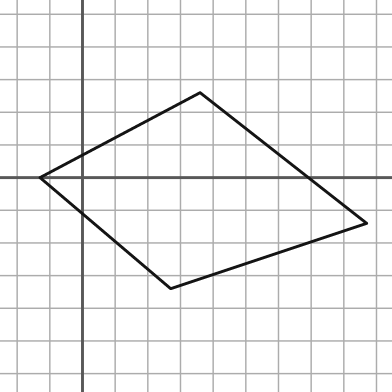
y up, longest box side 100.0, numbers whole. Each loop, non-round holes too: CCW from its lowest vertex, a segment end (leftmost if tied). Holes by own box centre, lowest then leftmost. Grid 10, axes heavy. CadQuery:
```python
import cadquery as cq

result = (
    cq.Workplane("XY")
    .moveTo(27.0, -34.0)
    .lineTo(87.0, -14.0)
    .lineTo(36.0, 26.0)
    .lineTo(-13.0, 0.0)
    .close()
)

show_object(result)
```